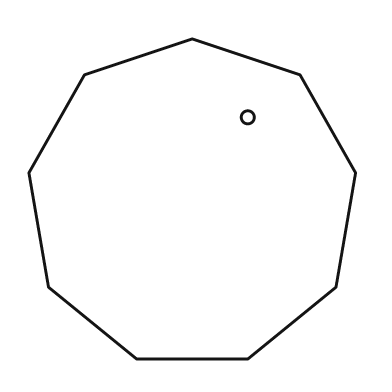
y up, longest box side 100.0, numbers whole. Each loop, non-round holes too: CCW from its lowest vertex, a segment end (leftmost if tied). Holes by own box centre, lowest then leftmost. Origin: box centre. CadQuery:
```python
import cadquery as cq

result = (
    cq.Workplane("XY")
    .moveTo(-17.0, -49.0)
    .lineTo(17.0, -49.0)
    .lineTo(44.0, -27.0)
    .lineTo(50.0, 8.0)
    .lineTo(33.0, 38.0)
    .lineTo(0.0, 49.0)
    .lineTo(-33.0, 38.0)
    .lineTo(-50.0, 8.0)
    .lineTo(-44.0, -27.0)
    .close()
    .moveTo(17.0, 25.0)
    .circle(2.0)
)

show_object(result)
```